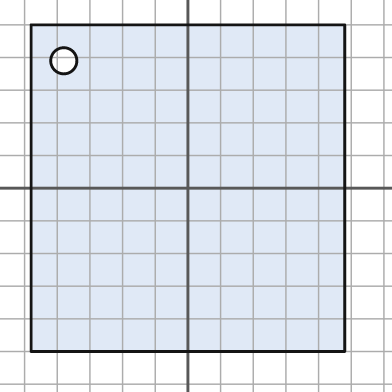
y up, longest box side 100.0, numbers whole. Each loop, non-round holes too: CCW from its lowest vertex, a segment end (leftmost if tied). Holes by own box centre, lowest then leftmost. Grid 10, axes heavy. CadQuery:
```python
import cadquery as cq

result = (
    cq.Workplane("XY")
    .moveTo(-48.0, -50.0)
    .lineTo(48.0, -50.0)
    .lineTo(48.0, 50.0)
    .lineTo(-48.0, 50.0)
    .close()
    .moveTo(-38.0, 39.0)
    .circle(4.0)
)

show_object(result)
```